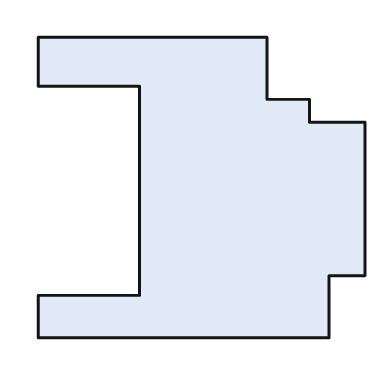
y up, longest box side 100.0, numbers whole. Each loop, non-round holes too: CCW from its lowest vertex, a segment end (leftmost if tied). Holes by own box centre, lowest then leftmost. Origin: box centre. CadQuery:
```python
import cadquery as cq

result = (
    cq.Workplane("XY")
    .moveTo(-50.0, -46.0)
    .lineTo(39.0, -46.0)
    .lineTo(39.0, -27.0)
    .lineTo(50.0, -27.0)
    .lineTo(50.0, 20.0)
    .lineTo(33.0, 20.0)
    .lineTo(33.0, 27.0)
    .lineTo(20.0, 27.0)
    .lineTo(20.0, 46.0)
    .lineTo(-50.0, 46.0)
    .lineTo(-50.0, 31.0)
    .lineTo(-19.0, 31.0)
    .lineTo(-19.0, -33.0)
    .lineTo(-50.0, -33.0)
    .close()
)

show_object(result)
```